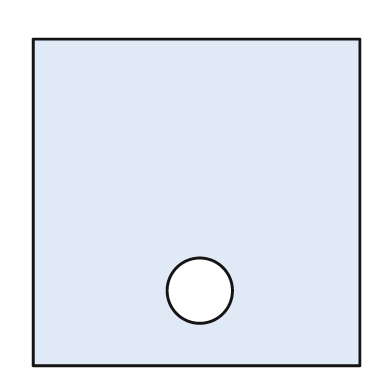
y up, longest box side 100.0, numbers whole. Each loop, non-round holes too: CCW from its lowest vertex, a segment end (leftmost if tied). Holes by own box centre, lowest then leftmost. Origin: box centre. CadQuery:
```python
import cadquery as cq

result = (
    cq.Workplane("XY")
    .moveTo(-50.0, -50.0)
    .lineTo(50.0, -50.0)
    .lineTo(50.0, 50.0)
    .lineTo(-50.0, 50.0)
    .close()
    .moveTo(1.0, -27.0)
    .circle(10.0)
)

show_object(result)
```